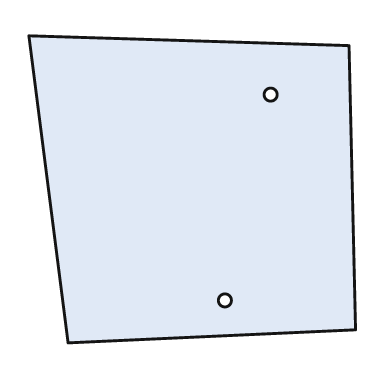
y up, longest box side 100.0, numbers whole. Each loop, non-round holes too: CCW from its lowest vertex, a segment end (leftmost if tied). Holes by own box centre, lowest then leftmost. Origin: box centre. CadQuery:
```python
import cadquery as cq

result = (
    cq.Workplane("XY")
    .moveTo(-38.0, -47.0)
    .lineTo(50.0, -43.0)
    .lineTo(48.0, 44.0)
    .lineTo(-50.0, 47.0)
    .close()
    .moveTo(10.0, -34.0)
    .circle(2.0)
    .moveTo(24.0, 29.0)
    .circle(2.0)
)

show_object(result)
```